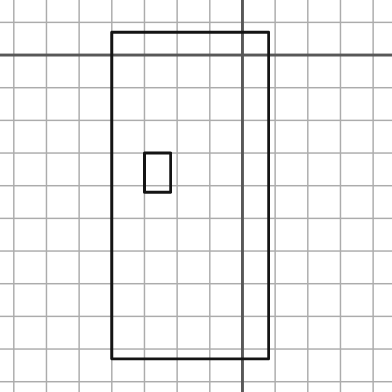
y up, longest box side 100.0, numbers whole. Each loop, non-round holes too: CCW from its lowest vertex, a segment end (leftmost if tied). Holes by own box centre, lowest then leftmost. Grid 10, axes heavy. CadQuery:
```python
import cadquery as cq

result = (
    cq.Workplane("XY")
    .moveTo(-40.0, -93.0)
    .lineTo(8.0, -93.0)
    .lineTo(8.0, 7.0)
    .lineTo(-40.0, 7.0)
    .close()
    .moveTo(-30.0, -42.0)
    .lineTo(-22.0, -42.0)
    .lineTo(-22.0, -30.0)
    .lineTo(-30.0, -30.0)
    .close()
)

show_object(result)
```